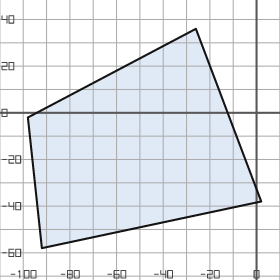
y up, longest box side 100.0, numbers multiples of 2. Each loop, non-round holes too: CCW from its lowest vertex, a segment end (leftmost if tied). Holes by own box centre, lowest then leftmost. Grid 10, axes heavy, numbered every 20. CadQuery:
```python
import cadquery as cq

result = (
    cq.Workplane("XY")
    .moveTo(-92.0, -58.0)
    .lineTo(2.0, -38.0)
    .lineTo(-26.0, 36.0)
    .lineTo(-98.0, -2.0)
    .close()
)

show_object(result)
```